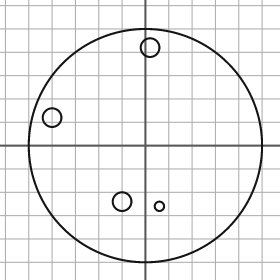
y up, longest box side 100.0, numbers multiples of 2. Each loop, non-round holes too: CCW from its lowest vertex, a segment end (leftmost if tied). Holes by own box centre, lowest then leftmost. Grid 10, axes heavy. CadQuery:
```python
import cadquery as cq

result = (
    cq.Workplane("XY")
    .moveTo(0.0, 0.0)
    .circle(50.0)
    .moveTo(6.0, -26.0)
    .circle(2.0)
    .moveTo(-10.0, -24.0)
    .circle(4.0)
    .moveTo(-40.0, 12.0)
    .circle(4.0)
    .moveTo(2.0, 42.0)
    .circle(4.0)
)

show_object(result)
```